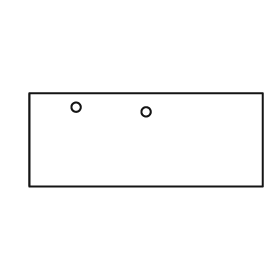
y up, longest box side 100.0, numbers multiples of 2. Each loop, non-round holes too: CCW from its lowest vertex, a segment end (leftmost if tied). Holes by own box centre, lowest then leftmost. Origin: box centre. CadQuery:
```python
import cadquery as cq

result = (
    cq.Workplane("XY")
    .moveTo(-50.0, -20.0)
    .lineTo(50.0, -20.0)
    .lineTo(50.0, 20.0)
    .lineTo(-50.0, 20.0)
    .close()
    .moveTo(0.0, 12.0)
    .circle(2.0)
    .moveTo(-30.0, 14.0)
    .circle(2.0)
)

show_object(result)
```